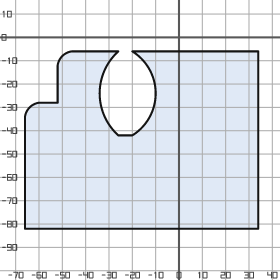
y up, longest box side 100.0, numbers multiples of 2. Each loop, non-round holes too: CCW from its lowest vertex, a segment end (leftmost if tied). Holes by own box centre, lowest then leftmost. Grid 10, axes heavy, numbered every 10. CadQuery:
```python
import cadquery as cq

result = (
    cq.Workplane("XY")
    .moveTo(-66.0, -82.0)
    .lineTo(34.0, -82.0)
    .lineTo(34.0, -6.0)
    .lineTo(-20.0, -6.0)
    .threePointArc((-10.0, -24.0), (-20.0, -42.0))
    .lineTo(-26.0, -42.0)
    .threePointArc((-34.0, -24.0), (-26.0, -6.0))
    .lineTo(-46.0, -6.0)
    .threePointArc((-50.0, -8.0), (-52.0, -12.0))
    .lineTo(-52.0, -28.0)
    .lineTo(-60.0, -28.0)
    .threePointArc((-64.0, -30.0), (-66.0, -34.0))
    .close()
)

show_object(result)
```